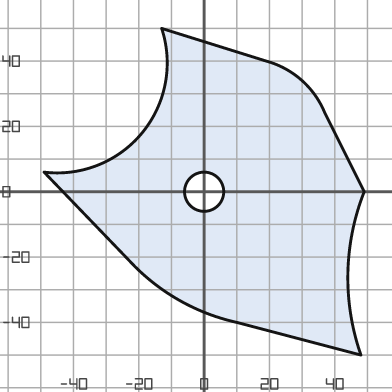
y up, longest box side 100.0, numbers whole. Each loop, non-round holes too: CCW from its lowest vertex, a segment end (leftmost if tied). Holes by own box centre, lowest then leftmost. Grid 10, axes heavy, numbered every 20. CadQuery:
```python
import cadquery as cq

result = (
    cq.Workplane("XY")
    .moveTo(48.0, -50.0)
    .threePointArc((44.0, -25.0), (49.0, 0.0))
    .lineTo(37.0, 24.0)
    .threePointArc((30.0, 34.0), (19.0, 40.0))
    .lineTo(-13.0, 50.0)
    .threePointArc((-19.0, 18.0), (-49.0, 6.0))
    .lineTo(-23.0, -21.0)
    .threePointArc((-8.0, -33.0), (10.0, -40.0))
    .close()
    .moveTo(0.0, 0.0)
    .circle(6.0)
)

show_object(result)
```